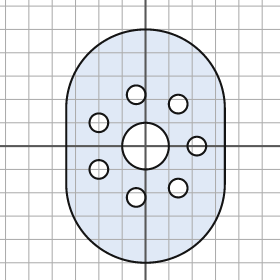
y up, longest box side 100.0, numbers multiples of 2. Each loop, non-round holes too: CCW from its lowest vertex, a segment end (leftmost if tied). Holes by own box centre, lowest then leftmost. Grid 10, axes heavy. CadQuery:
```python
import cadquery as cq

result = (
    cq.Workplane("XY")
    .moveTo(-34.0, -16.0)
    .threePointArc((0.0, -50.0), (34.0, -16.0))
    .lineTo(34.0, 16.0)
    .threePointArc((0.0, 50.0), (-34.0, 16.0))
    .close()
    .moveTo(-4.0, -22.0)
    .circle(4.0)
    .moveTo(14.0, -18.0)
    .circle(4.0)
    .moveTo(-20.0, -10.0)
    .circle(4.0)
    .moveTo(0.0, 0.0)
    .circle(10.0)
    .moveTo(22.0, 0.0)
    .circle(4.0)
    .moveTo(-20.0, 10.0)
    .circle(4.0)
    .moveTo(14.0, 18.0)
    .circle(4.0)
    .moveTo(-4.0, 22.0)
    .circle(4.0)
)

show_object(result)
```